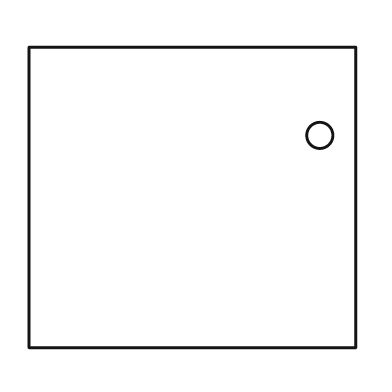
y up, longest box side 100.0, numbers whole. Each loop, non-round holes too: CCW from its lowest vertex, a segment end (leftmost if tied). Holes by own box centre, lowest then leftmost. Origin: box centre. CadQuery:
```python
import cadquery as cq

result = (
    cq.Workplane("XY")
    .moveTo(-50.0, -46.0)
    .lineTo(50.0, -46.0)
    .lineTo(50.0, 46.0)
    .lineTo(-50.0, 46.0)
    .close()
    .moveTo(39.0, 19.0)
    .circle(4.0)
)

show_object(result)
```